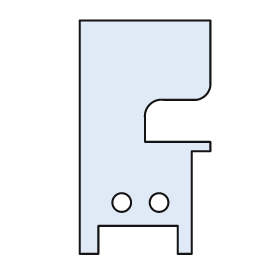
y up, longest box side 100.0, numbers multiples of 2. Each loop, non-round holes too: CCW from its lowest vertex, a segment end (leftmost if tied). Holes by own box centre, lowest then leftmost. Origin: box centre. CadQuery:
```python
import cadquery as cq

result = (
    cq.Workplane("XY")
    .moveTo(-28.0, -50.0)
    .lineTo(-20.0, -50.0)
    .lineTo(-20.0, -38.0)
    .lineTo(14.0, -38.0)
    .lineTo(14.0, -50.0)
    .lineTo(20.0, -50.0)
    .lineTo(20.0, -6.0)
    .lineTo(28.0, -6.0)
    .lineTo(28.0, -2.0)
    .lineTo(0.0, -2.0)
    .lineTo(0.0, 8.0)
    .threePointArc((2.0, 14.0), (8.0, 16.0))
    .lineTo(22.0, 16.0)
    .threePointArc((26.0, 18.0), (28.0, 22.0))
    .lineTo(28.0, 50.0)
    .lineTo(-28.0, 50.0)
    .close()
    .moveTo(-10.0, -28.0)
    .circle(4.0)
    .moveTo(6.0, -28.0)
    .circle(4.0)
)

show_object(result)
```